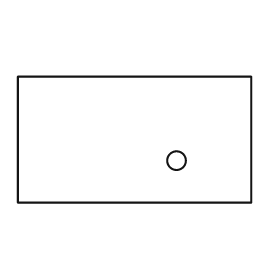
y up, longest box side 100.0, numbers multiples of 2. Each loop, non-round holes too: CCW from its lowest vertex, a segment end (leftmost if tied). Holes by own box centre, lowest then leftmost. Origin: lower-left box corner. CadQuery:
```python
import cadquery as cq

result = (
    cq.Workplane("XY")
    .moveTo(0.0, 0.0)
    .lineTo(100.0, 0.0)
    .lineTo(100.0, 54.0)
    .lineTo(0.0, 54.0)
    .close()
    .moveTo(68.0, 18.0)
    .circle(4.0)
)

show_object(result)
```